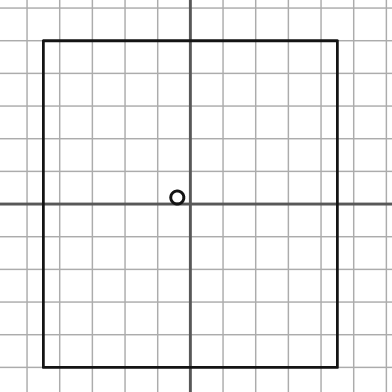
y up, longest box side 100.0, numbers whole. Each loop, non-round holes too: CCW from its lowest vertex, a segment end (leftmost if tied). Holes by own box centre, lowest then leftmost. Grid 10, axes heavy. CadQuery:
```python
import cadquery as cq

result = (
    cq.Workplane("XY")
    .moveTo(-45.0, -50.0)
    .lineTo(45.0, -50.0)
    .lineTo(45.0, 50.0)
    .lineTo(-45.0, 50.0)
    .close()
    .moveTo(-4.0, 2.0)
    .circle(2.0)
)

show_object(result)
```